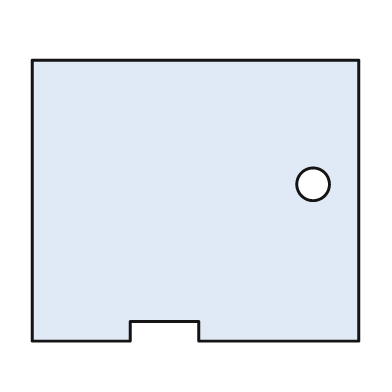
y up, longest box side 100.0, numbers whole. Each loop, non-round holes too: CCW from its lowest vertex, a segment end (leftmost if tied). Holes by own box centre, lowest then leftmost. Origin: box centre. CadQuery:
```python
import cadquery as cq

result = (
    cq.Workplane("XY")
    .moveTo(-50.0, -43.0)
    .lineTo(-20.0, -43.0)
    .lineTo(-20.0, -37.0)
    .lineTo(1.0, -37.0)
    .lineTo(1.0, -43.0)
    .lineTo(50.0, -43.0)
    .lineTo(50.0, 43.0)
    .lineTo(-50.0, 43.0)
    .close()
    .moveTo(36.0, 5.0)
    .circle(5.0)
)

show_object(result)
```